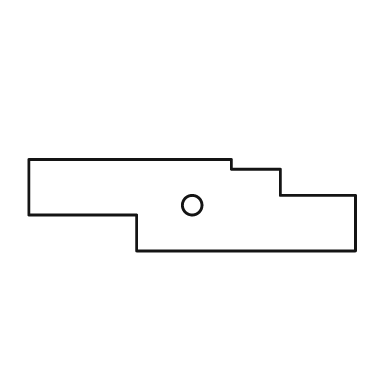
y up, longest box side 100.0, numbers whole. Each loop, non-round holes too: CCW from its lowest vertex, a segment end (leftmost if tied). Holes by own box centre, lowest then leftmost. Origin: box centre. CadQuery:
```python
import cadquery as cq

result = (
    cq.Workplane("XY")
    .moveTo(-17.0, -14.0)
    .lineTo(50.0, -14.0)
    .lineTo(50.0, 3.0)
    .lineTo(27.0, 3.0)
    .lineTo(27.0, 11.0)
    .lineTo(12.0, 11.0)
    .lineTo(12.0, 14.0)
    .lineTo(-50.0, 14.0)
    .lineTo(-50.0, -3.0)
    .lineTo(-17.0, -3.0)
    .close()
    .moveTo(0.0, 0.0)
    .circle(3.0)
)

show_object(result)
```